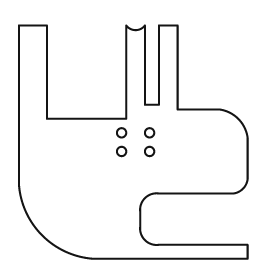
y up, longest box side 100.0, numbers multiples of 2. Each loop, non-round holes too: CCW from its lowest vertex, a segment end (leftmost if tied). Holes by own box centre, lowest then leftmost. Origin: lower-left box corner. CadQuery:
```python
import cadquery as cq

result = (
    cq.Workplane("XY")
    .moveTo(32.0, 0.0)
    .lineTo(98.0, 0.0)
    .lineTo(98.0, 6.0)
    .lineTo(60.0, 6.0)
    .threePointArc((54.0, 8.0), (52.0, 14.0))
    .lineTo(52.0, 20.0)
    .threePointArc((54.0, 26.0), (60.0, 28.0))
    .lineTo(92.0, 28.0)
    .threePointArc((96.0, 30.0), (98.0, 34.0))
    .lineTo(98.0, 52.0)
    .threePointArc((94.0, 60.0), (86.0, 64.0))
    .lineTo(68.0, 64.0)
    .lineTo(68.0, 100.0)
    .lineTo(60.0, 100.0)
    .lineTo(60.0, 66.0)
    .lineTo(54.0, 66.0)
    .lineTo(54.0, 100.0)
    .threePointArc((50.0, 98.0), (46.0, 100.0))
    .lineTo(46.0, 60.0)
    .lineTo(12.0, 60.0)
    .lineTo(12.0, 100.0)
    .lineTo(0.0, 100.0)
    .lineTo(0.0, 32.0)
    .threePointArc((10.0, 10.0), (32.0, 0.0))
    .close()
    .moveTo(44.0, 46.0)
    .circle(2.0)
    .moveTo(56.0, 46.0)
    .circle(2.0)
    .moveTo(44.0, 54.0)
    .circle(2.0)
    .moveTo(56.0, 54.0)
    .circle(2.0)
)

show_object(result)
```